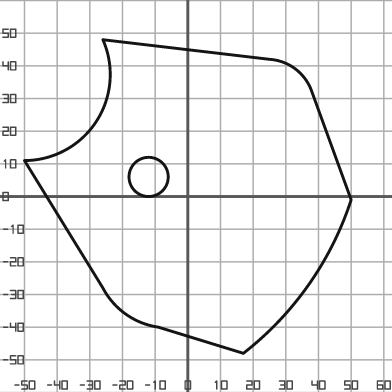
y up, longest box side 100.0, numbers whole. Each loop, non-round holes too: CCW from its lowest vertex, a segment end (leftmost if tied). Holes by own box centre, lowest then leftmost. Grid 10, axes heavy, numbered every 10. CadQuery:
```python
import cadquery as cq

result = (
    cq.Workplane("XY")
    .moveTo(17.0, -48.0)
    .threePointArc((37.0, -27.0), (50.0, -1.0))
    .lineTo(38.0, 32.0)
    .threePointArc((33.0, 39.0), (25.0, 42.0))
    .lineTo(-26.0, 48.0)
    .threePointArc((-28.0, 23.0), (-50.0, 11.0))
    .lineTo(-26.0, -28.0)
    .threePointArc((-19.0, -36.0), (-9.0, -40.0))
    .close()
    .moveTo(-12.0, 6.0)
    .circle(6.0)
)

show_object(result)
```